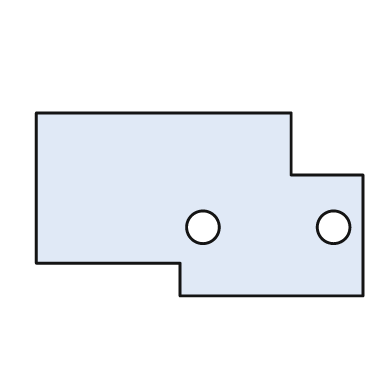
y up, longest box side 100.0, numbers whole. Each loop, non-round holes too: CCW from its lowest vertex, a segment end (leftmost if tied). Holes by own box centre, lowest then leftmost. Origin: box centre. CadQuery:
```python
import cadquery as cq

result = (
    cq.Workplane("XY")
    .moveTo(-6.0, -28.0)
    .lineTo(50.0, -28.0)
    .lineTo(50.0, 9.0)
    .lineTo(28.0, 9.0)
    .lineTo(28.0, 28.0)
    .lineTo(-50.0, 28.0)
    .lineTo(-50.0, -18.0)
    .lineTo(-6.0, -18.0)
    .close()
    .moveTo(1.0, -7.0)
    .circle(5.0)
    .moveTo(41.0, -7.0)
    .circle(5.0)
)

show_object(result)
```